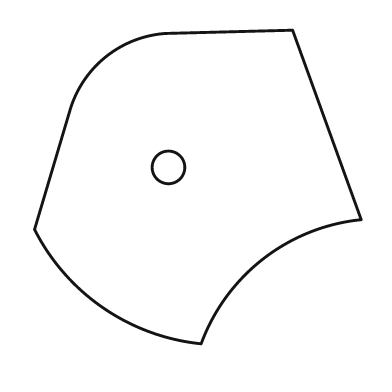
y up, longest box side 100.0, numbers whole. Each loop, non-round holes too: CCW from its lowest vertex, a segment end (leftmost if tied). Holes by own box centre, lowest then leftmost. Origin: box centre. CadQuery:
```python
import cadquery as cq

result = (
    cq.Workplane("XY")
    .moveTo(1.0, -48.0)
    .threePointArc((20.0, -22.0), (50.0, -10.0))
    .lineTo(29.0, 48.0)
    .lineTo(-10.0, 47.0)
    .threePointArc((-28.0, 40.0), (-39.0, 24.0))
    .lineTo(-50.0, -13.0)
    .threePointArc((-29.0, -37.0), (1.0, -48.0))
    .close()
    .moveTo(-9.0, 6.0)
    .circle(5.0)
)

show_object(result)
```